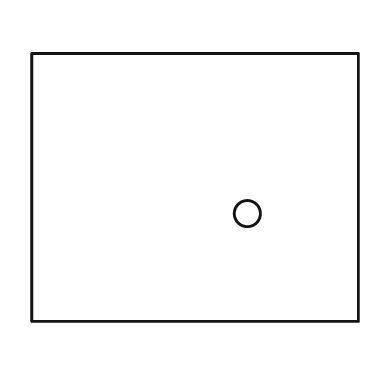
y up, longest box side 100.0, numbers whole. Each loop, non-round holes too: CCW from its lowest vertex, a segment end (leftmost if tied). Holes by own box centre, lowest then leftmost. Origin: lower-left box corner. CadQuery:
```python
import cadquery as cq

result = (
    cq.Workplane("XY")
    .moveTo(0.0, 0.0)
    .lineTo(100.0, 0.0)
    .lineTo(100.0, 82.0)
    .lineTo(0.0, 82.0)
    .close()
    .moveTo(66.0, 33.0)
    .circle(4.0)
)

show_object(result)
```